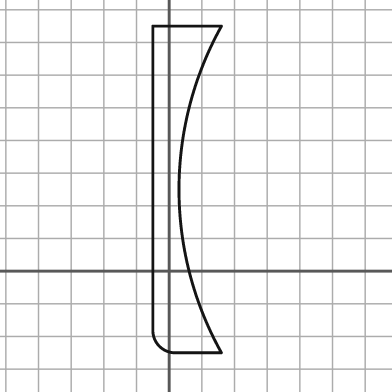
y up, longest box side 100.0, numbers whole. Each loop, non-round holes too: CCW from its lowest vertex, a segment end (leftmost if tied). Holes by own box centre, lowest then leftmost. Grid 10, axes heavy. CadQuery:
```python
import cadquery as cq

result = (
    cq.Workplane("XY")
    .moveTo(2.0, -25.0)
    .lineTo(16.0, -25.0)
    .threePointArc((3.0, 25.0), (16.0, 75.0))
    .lineTo(-5.0, 75.0)
    .lineTo(-5.0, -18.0)
    .threePointArc((-3.0, -23.0), (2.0, -25.0))
    .close()
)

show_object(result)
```